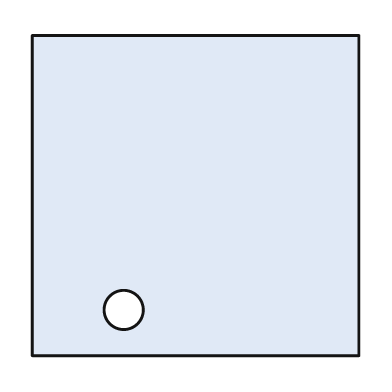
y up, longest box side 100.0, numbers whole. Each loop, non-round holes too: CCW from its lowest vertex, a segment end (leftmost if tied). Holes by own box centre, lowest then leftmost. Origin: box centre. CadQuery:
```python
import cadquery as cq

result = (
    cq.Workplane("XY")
    .moveTo(-50.0, -49.0)
    .lineTo(50.0, -49.0)
    .lineTo(50.0, 49.0)
    .lineTo(-50.0, 49.0)
    .close()
    .moveTo(-22.0, -35.0)
    .circle(6.0)
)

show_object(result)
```